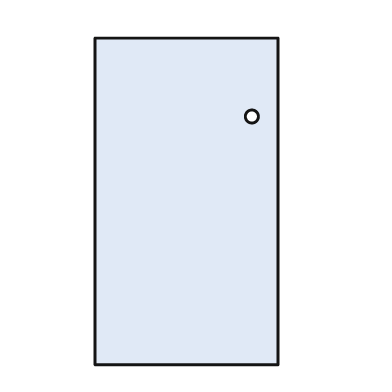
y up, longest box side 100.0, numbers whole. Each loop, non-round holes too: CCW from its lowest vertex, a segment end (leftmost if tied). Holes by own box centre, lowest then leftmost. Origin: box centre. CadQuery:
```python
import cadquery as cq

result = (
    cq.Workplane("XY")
    .moveTo(-28.0, -50.0)
    .lineTo(28.0, -50.0)
    .lineTo(28.0, 50.0)
    .lineTo(-28.0, 50.0)
    .close()
    .moveTo(20.0, 26.0)
    .circle(2.0)
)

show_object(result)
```